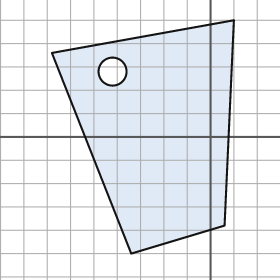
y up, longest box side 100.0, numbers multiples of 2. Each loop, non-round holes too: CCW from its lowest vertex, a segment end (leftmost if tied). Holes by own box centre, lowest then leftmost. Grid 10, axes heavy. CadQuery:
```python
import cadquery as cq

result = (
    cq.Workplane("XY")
    .moveTo(-34.0, -50.0)
    .lineTo(6.0, -38.0)
    .lineTo(10.0, 50.0)
    .lineTo(-68.0, 36.0)
    .close()
    .moveTo(-42.0, 28.0)
    .circle(6.0)
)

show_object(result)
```